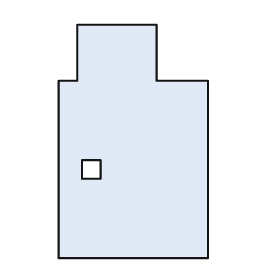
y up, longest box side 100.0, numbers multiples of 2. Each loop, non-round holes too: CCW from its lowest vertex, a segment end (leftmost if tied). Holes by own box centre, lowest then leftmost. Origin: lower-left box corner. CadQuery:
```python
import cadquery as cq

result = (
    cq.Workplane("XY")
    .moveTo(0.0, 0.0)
    .lineTo(64.0, 0.0)
    .lineTo(64.0, 76.0)
    .lineTo(42.0, 76.0)
    .lineTo(42.0, 100.0)
    .lineTo(8.0, 100.0)
    .lineTo(8.0, 76.0)
    .lineTo(0.0, 76.0)
    .close()
    .moveTo(10.0, 34.0)
    .lineTo(18.0, 34.0)
    .lineTo(18.0, 42.0)
    .lineTo(10.0, 42.0)
    .close()
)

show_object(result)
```